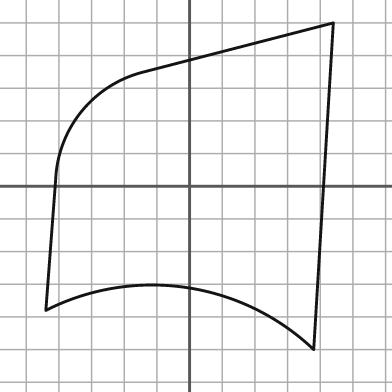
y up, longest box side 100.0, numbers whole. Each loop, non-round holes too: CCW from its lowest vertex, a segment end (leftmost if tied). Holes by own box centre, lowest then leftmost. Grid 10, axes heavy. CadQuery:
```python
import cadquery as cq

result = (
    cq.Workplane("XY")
    .moveTo(38.0, -50.0)
    .lineTo(44.0, 50.0)
    .lineTo(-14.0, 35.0)
    .threePointArc((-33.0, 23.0), (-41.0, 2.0))
    .lineTo(-44.0, -38.0)
    .threePointArc((-1.0, -31.0), (38.0, -50.0))
    .close()
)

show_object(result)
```